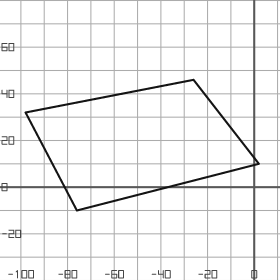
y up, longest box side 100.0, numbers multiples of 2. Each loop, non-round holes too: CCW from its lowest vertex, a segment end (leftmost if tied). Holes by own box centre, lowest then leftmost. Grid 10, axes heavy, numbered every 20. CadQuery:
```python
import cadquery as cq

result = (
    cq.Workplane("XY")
    .moveTo(-76.0, -10.0)
    .lineTo(2.0, 10.0)
    .lineTo(-26.0, 46.0)
    .lineTo(-98.0, 32.0)
    .close()
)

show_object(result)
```